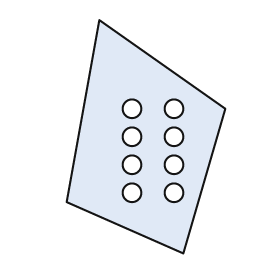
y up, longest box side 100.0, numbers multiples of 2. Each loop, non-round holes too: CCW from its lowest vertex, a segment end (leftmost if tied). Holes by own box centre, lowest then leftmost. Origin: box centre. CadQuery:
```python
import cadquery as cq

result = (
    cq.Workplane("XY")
    .moveTo(16.0, -50.0)
    .lineTo(34.0, 12.0)
    .lineTo(-20.0, 50.0)
    .lineTo(-34.0, -28.0)
    .close()
    .moveTo(-6.0, -24.0)
    .circle(4.0)
    .moveTo(12.0, -24.0)
    .circle(4.0)
    .moveTo(-6.0, -12.0)
    .circle(4.0)
    .moveTo(12.0, -12.0)
    .circle(4.0)
    .moveTo(-6.0, 0.0)
    .circle(4.0)
    .moveTo(12.0, 0.0)
    .circle(4.0)
    .moveTo(-6.0, 12.0)
    .circle(4.0)
    .moveTo(12.0, 12.0)
    .circle(4.0)
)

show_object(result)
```